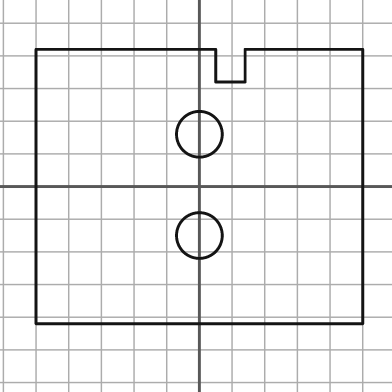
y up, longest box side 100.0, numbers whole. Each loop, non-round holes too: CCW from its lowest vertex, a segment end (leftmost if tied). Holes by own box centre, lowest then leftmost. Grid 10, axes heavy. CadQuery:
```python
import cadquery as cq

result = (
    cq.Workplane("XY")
    .moveTo(-50.0, -42.0)
    .lineTo(50.0, -42.0)
    .lineTo(50.0, 42.0)
    .lineTo(14.0, 42.0)
    .lineTo(14.0, 32.0)
    .lineTo(5.0, 32.0)
    .lineTo(5.0, 42.0)
    .lineTo(-50.0, 42.0)
    .close()
    .moveTo(0.0, -15.0)
    .circle(7.0)
    .moveTo(0.0, 16.0)
    .circle(7.0)
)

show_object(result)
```